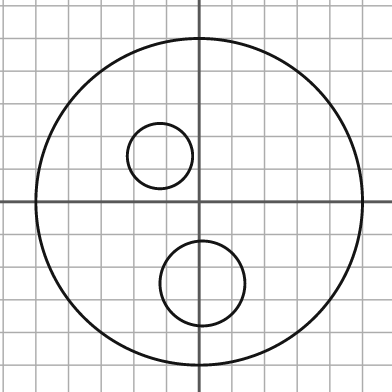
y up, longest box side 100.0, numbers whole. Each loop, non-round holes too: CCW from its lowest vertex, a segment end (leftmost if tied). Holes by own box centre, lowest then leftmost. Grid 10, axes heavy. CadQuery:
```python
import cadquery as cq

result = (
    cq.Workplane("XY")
    .moveTo(0.0, 0.0)
    .circle(50.0)
    .moveTo(1.0, -25.0)
    .circle(13.0)
    .moveTo(-12.0, 14.0)
    .circle(10.0)
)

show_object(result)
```